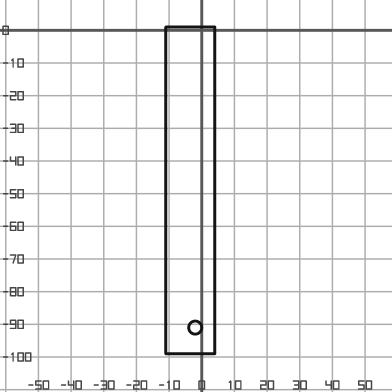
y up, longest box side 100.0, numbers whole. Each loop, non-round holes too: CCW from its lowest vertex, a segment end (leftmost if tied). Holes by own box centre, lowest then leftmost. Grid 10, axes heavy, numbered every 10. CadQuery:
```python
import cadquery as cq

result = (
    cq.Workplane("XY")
    .moveTo(-11.0, -99.0)
    .lineTo(4.0, -99.0)
    .lineTo(4.0, 1.0)
    .lineTo(-11.0, 1.0)
    .close()
    .moveTo(-2.0, -91.0)
    .circle(2.0)
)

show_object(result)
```